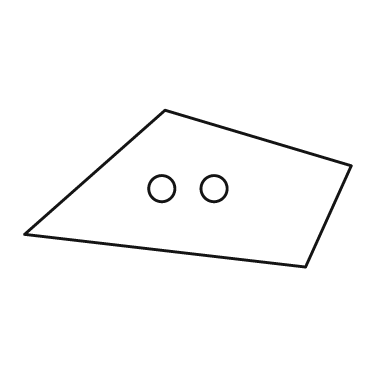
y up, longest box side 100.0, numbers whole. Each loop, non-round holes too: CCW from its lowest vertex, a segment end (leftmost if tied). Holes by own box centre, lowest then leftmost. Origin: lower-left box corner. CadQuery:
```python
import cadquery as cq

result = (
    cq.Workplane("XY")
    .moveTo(86.0, 0.0)
    .lineTo(100.0, 31.0)
    .lineTo(43.0, 48.0)
    .lineTo(0.0, 10.0)
    .close()
    .moveTo(42.0, 24.0)
    .circle(4.0)
    .moveTo(58.0, 24.0)
    .circle(4.0)
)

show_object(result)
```